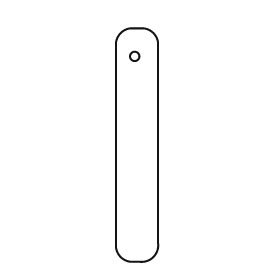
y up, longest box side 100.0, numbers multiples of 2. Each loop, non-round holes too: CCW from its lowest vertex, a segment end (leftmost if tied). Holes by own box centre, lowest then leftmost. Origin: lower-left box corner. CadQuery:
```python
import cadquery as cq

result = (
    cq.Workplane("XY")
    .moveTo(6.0, 0.0)
    .lineTo(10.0, 0.0)
    .threePointArc((16.0, 2.0), (18.0, 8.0))
    .lineTo(18.0, 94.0)
    .threePointArc((16.0, 98.0), (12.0, 100.0))
    .lineTo(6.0, 100.0)
    .threePointArc((2.0, 98.0), (0.0, 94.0))
    .lineTo(0.0, 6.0)
    .threePointArc((2.0, 2.0), (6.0, 0.0))
    .close()
    .moveTo(8.0, 88.0)
    .circle(2.0)
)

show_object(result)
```